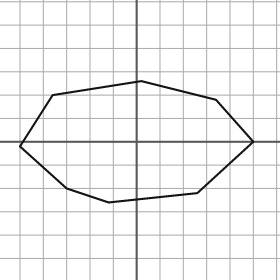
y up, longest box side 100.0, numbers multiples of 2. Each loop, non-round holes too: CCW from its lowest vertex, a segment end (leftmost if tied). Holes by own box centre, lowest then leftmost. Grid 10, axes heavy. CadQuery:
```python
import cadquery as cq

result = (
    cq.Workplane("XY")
    .moveTo(-12.0, -26.0)
    .lineTo(26.0, -22.0)
    .lineTo(50.0, 0.0)
    .lineTo(34.0, 18.0)
    .lineTo(2.0, 26.0)
    .lineTo(-36.0, 20.0)
    .lineTo(-50.0, -2.0)
    .lineTo(-30.0, -20.0)
    .close()
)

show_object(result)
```